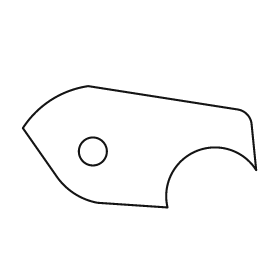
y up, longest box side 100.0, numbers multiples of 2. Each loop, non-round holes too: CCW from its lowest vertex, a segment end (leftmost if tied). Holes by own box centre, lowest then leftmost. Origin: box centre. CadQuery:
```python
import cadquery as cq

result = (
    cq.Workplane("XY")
    .moveTo(12.0, -26.0)
    .threePointArc((24.0, -2.0), (50.0, -10.0))
    .lineTo(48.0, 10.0)
    .threePointArc((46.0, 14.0), (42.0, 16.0))
    .lineTo(-22.0, 26.0)
    .threePointArc((-38.0, 20.0), (-50.0, 8.0))
    .lineTo(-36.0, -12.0)
    .threePointArc((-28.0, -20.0), (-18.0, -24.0))
    .close()
    .moveTo(-20.0, -2.0)
    .circle(6.0)
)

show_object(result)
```